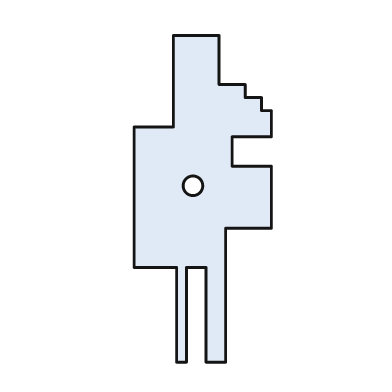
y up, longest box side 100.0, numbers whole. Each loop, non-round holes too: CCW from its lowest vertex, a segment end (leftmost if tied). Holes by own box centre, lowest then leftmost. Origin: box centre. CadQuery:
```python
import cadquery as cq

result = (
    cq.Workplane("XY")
    .moveTo(-8.0, -50.0)
    .lineTo(-5.0, -50.0)
    .lineTo(-5.0, -21.0)
    .lineTo(1.0, -21.0)
    .lineTo(1.0, -50.0)
    .lineTo(7.0, -50.0)
    .lineTo(7.0, -9.0)
    .lineTo(21.0, -9.0)
    .lineTo(21.0, 10.0)
    .lineTo(9.0, 10.0)
    .lineTo(9.0, 19.0)
    .lineTo(21.0, 19.0)
    .lineTo(21.0, 27.0)
    .lineTo(18.0, 27.0)
    .lineTo(18.0, 31.0)
    .lineTo(13.0, 31.0)
    .lineTo(13.0, 35.0)
    .lineTo(5.0, 35.0)
    .lineTo(5.0, 50.0)
    .lineTo(-9.0, 50.0)
    .lineTo(-9.0, 22.0)
    .lineTo(-21.0, 22.0)
    .lineTo(-21.0, -21.0)
    .lineTo(-8.0, -21.0)
    .close()
    .moveTo(-3.0, 4.0)
    .circle(3.0)
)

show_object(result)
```